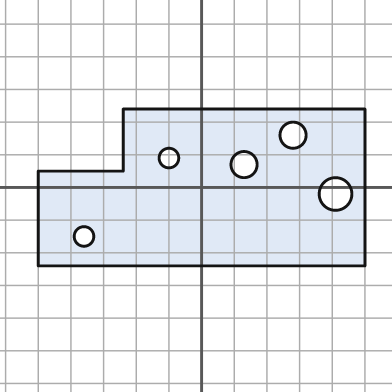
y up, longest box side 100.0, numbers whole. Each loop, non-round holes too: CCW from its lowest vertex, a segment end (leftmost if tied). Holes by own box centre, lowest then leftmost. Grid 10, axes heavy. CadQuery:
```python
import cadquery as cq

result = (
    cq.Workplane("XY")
    .moveTo(-50.0, -24.0)
    .lineTo(50.0, -24.0)
    .lineTo(50.0, 24.0)
    .lineTo(-24.0, 24.0)
    .lineTo(-24.0, 5.0)
    .lineTo(-50.0, 5.0)
    .close()
    .moveTo(-36.0, -15.0)
    .circle(3.0)
    .moveTo(41.0, -2.0)
    .circle(5.0)
    .moveTo(13.0, 7.0)
    .circle(4.0)
    .moveTo(-10.0, 9.0)
    .circle(3.0)
    .moveTo(28.0, 16.0)
    .circle(4.0)
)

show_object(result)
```